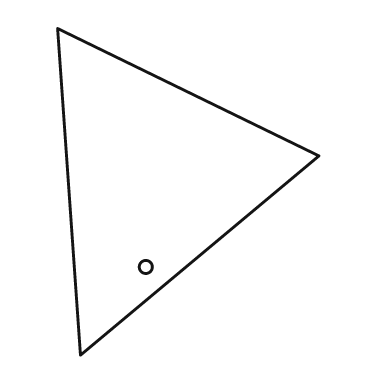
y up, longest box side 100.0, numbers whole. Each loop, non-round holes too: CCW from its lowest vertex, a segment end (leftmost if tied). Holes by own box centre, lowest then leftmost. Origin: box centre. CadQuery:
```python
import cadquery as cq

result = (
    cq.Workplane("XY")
    .moveTo(-33.0, -50.0)
    .lineTo(40.0, 11.0)
    .lineTo(-40.0, 50.0)
    .close()
    .moveTo(-13.0, -23.0)
    .circle(2.0)
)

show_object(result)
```